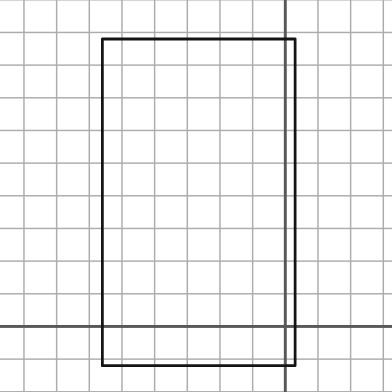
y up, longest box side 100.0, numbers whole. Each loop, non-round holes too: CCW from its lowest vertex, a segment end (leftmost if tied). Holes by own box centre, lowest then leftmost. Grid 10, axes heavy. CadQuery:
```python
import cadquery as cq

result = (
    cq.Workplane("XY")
    .moveTo(-56.0, -12.0)
    .lineTo(3.0, -12.0)
    .lineTo(3.0, 88.0)
    .lineTo(-56.0, 88.0)
    .close()
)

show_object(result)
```